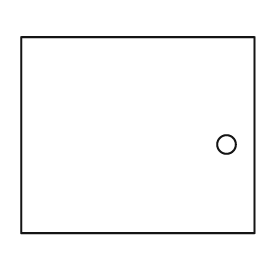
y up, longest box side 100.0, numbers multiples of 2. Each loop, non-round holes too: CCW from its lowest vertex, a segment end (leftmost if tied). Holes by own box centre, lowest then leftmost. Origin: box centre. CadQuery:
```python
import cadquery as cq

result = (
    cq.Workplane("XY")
    .moveTo(-50.0, -42.0)
    .lineTo(50.0, -42.0)
    .lineTo(50.0, 42.0)
    .lineTo(-50.0, 42.0)
    .close()
    .moveTo(38.0, -4.0)
    .circle(4.0)
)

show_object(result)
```